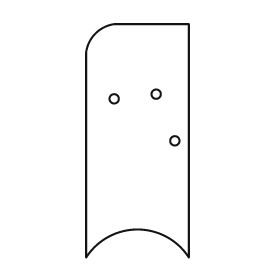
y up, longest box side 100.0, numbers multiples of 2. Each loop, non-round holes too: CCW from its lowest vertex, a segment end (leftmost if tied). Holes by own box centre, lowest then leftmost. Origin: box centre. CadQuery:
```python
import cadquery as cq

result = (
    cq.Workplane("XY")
    .moveTo(-22.0, -50.0)
    .threePointArc((0.0, -38.0), (22.0, -50.0))
    .lineTo(22.0, 50.0)
    .lineTo(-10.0, 50.0)
    .threePointArc((-18.0, 46.0), (-22.0, 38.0))
    .close()
    .moveTo(16.0, 0.0)
    .circle(2.0)
    .moveTo(-10.0, 18.0)
    .circle(2.0)
    .moveTo(8.0, 20.0)
    .circle(2.0)
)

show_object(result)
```